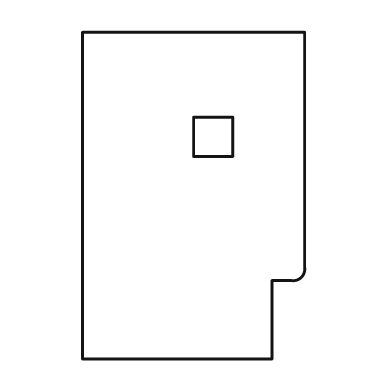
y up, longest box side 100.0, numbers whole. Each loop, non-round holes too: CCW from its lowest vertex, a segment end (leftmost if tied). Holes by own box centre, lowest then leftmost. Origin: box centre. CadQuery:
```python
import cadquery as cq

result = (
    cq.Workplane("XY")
    .moveTo(-34.0, -50.0)
    .lineTo(24.0, -50.0)
    .lineTo(24.0, -26.0)
    .lineTo(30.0, -26.0)
    .threePointArc((33.0, -25.0), (34.0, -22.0))
    .lineTo(34.0, 50.0)
    .lineTo(-34.0, 50.0)
    .close()
    .moveTo(0.0, 12.0)
    .lineTo(12.0, 12.0)
    .lineTo(12.0, 24.0)
    .lineTo(0.0, 24.0)
    .close()
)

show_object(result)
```